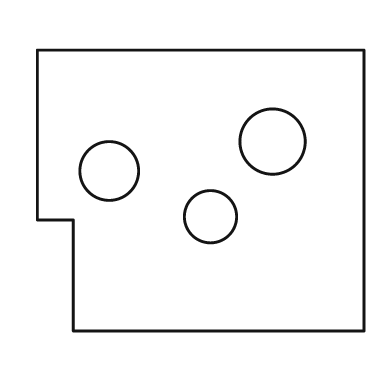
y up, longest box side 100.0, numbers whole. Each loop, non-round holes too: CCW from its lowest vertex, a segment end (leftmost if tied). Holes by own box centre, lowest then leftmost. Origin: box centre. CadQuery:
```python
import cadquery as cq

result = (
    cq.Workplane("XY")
    .moveTo(-39.0, -43.0)
    .lineTo(50.0, -43.0)
    .lineTo(50.0, 43.0)
    .lineTo(-50.0, 43.0)
    .lineTo(-50.0, -9.0)
    .lineTo(-39.0, -9.0)
    .close()
    .moveTo(3.0, -8.0)
    .circle(8.0)
    .moveTo(-28.0, 6.0)
    .circle(9.0)
    .moveTo(22.0, 15.0)
    .circle(10.0)
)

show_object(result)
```